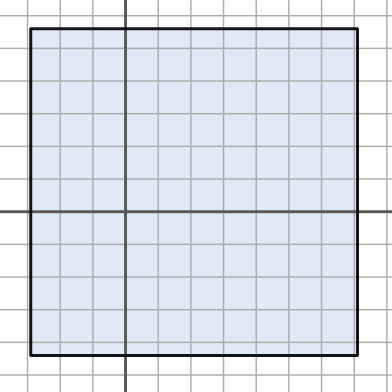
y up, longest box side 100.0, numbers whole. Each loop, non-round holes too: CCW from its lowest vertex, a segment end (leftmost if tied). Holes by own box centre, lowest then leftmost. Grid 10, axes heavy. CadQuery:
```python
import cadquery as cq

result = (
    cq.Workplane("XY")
    .moveTo(-29.0, -44.0)
    .lineTo(71.0, -44.0)
    .lineTo(71.0, 56.0)
    .lineTo(-29.0, 56.0)
    .close()
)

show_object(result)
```